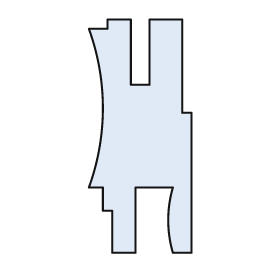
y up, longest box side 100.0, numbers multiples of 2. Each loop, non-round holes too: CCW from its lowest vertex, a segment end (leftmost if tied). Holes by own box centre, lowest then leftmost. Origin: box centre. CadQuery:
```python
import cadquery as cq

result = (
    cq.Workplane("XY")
    .moveTo(-12.0, -50.0)
    .lineTo(-2.0, -50.0)
    .lineTo(-2.0, -22.0)
    .lineTo(14.0, -22.0)
    .threePointArc((12.0, -36.0), (14.0, -50.0))
    .lineTo(22.0, -50.0)
    .lineTo(22.0, 10.0)
    .lineTo(18.0, 10.0)
    .lineTo(18.0, 50.0)
    .lineTo(4.0, 50.0)
    .lineTo(4.0, 22.0)
    .lineTo(-4.0, 22.0)
    .lineTo(-4.0, 50.0)
    .lineTo(-14.0, 50.0)
    .lineTo(-14.0, 46.0)
    .lineTo(-22.0, 46.0)
    .threePointArc((-16.0, 12.0), (-22.0, -22.0))
    .lineTo(-16.0, -22.0)
    .lineTo(-16.0, -32.0)
    .lineTo(-12.0, -32.0)
    .close()
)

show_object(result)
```